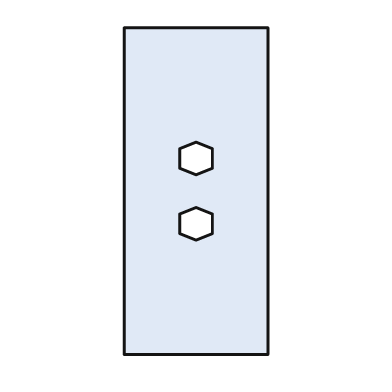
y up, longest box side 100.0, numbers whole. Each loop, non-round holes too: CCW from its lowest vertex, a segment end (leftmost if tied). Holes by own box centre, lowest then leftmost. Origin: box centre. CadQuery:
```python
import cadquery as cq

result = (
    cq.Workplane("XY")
    .moveTo(-22.0, -50.0)
    .lineTo(22.0, -50.0)
    .lineTo(22.0, 50.0)
    .lineTo(-22.0, 50.0)
    .close()
    .moveTo(0.0, -15.0)
    .lineTo(5.0, -13.0)
    .lineTo(5.0, -7.0)
    .lineTo(0.0, -5.0)
    .lineTo(-5.0, -7.0)
    .lineTo(-5.0, -13.0)
    .close()
    .moveTo(0.0, 5.0)
    .lineTo(5.0, 7.0)
    .lineTo(5.0, 13.0)
    .lineTo(0.0, 15.0)
    .lineTo(-5.0, 13.0)
    .lineTo(-5.0, 7.0)
    .close()
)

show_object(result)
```